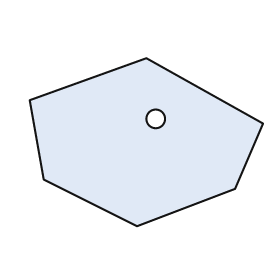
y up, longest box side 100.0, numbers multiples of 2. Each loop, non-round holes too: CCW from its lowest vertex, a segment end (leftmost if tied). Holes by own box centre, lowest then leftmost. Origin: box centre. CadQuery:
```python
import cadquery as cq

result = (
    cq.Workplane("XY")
    .moveTo(-4.0, -36.0)
    .lineTo(38.0, -20.0)
    .lineTo(50.0, 8.0)
    .lineTo(0.0, 36.0)
    .lineTo(-50.0, 18.0)
    .lineTo(-44.0, -16.0)
    .close()
    .moveTo(4.0, 10.0)
    .circle(4.0)
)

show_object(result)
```